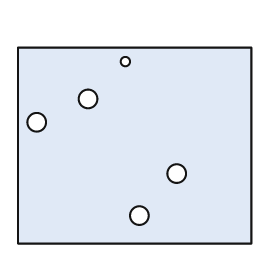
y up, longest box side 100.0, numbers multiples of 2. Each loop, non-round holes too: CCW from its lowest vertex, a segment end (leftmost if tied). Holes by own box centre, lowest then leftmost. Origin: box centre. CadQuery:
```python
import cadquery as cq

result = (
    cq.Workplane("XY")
    .moveTo(-50.0, -42.0)
    .lineTo(50.0, -42.0)
    .lineTo(50.0, 42.0)
    .lineTo(-50.0, 42.0)
    .close()
    .moveTo(2.0, -30.0)
    .circle(4.0)
    .moveTo(18.0, -12.0)
    .circle(4.0)
    .moveTo(-42.0, 10.0)
    .circle(4.0)
    .moveTo(-20.0, 20.0)
    .circle(4.0)
    .moveTo(-4.0, 36.0)
    .circle(2.0)
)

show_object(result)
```